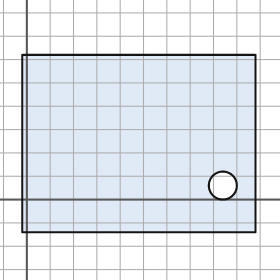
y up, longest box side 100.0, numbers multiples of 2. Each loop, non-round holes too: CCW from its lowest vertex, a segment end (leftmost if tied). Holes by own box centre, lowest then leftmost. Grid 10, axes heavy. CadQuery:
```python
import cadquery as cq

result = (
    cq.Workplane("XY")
    .moveTo(-2.0, -14.0)
    .lineTo(98.0, -14.0)
    .lineTo(98.0, 62.0)
    .lineTo(-2.0, 62.0)
    .close()
    .moveTo(84.0, 6.0)
    .circle(6.0)
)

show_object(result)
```